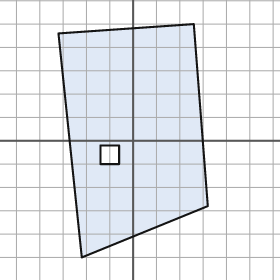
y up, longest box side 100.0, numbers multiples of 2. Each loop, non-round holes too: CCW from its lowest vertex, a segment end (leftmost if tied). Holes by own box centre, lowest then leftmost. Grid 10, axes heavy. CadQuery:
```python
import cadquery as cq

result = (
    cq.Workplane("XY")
    .moveTo(-22.0, -50.0)
    .lineTo(32.0, -28.0)
    .lineTo(26.0, 50.0)
    .lineTo(-32.0, 46.0)
    .close()
    .moveTo(-14.0, -10.0)
    .lineTo(-6.0, -10.0)
    .lineTo(-6.0, -2.0)
    .lineTo(-14.0, -2.0)
    .close()
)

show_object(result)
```